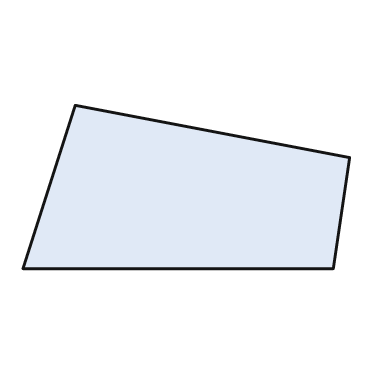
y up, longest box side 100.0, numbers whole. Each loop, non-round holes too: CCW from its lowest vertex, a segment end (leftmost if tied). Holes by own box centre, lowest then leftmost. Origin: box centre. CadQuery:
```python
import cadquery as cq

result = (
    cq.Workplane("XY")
    .moveTo(-50.0, -25.0)
    .lineTo(45.0, -25.0)
    .lineTo(50.0, 9.0)
    .lineTo(-34.0, 25.0)
    .close()
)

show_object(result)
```